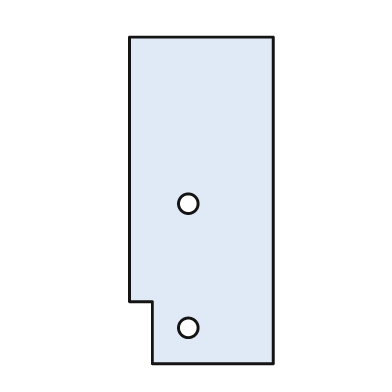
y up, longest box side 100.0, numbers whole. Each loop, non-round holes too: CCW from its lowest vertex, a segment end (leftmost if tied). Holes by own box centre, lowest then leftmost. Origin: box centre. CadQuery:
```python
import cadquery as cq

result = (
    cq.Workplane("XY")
    .moveTo(-15.0, -50.0)
    .lineTo(22.0, -50.0)
    .lineTo(22.0, 50.0)
    .lineTo(-22.0, 50.0)
    .lineTo(-22.0, -31.0)
    .lineTo(-15.0, -31.0)
    .close()
    .moveTo(-4.0, -39.0)
    .circle(3.0)
    .moveTo(-4.0, -1.0)
    .circle(3.0)
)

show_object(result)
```